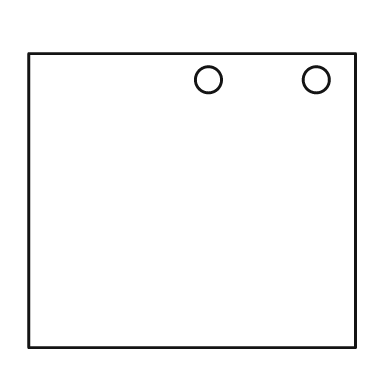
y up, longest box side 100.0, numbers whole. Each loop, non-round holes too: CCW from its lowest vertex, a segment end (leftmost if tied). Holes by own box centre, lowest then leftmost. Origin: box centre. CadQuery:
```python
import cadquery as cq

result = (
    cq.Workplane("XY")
    .moveTo(-50.0, -45.0)
    .lineTo(50.0, -45.0)
    .lineTo(50.0, 45.0)
    .lineTo(-50.0, 45.0)
    .close()
    .moveTo(5.0, 37.0)
    .circle(4.0)
    .moveTo(38.0, 37.0)
    .circle(4.0)
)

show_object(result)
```